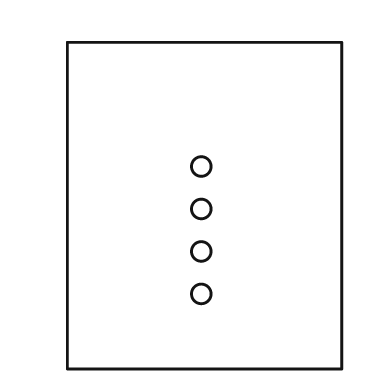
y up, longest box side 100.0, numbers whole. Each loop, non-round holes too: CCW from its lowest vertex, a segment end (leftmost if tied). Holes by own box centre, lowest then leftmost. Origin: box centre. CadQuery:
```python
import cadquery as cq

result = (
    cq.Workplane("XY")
    .moveTo(-42.0, -50.0)
    .lineTo(42.0, -50.0)
    .lineTo(42.0, 50.0)
    .lineTo(-42.0, 50.0)
    .close()
    .moveTo(-1.0, -27.0)
    .circle(3.0)
    .moveTo(-1.0, -14.0)
    .circle(3.0)
    .moveTo(-1.0, -1.0)
    .circle(3.0)
    .moveTo(-1.0, 12.0)
    .circle(3.0)
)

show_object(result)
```